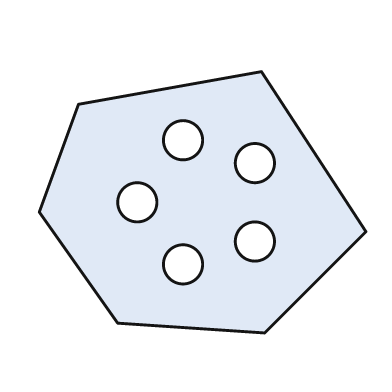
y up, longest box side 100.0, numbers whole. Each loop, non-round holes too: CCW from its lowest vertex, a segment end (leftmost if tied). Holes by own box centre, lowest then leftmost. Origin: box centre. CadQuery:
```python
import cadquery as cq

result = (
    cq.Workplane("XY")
    .moveTo(19.0, -40.0)
    .lineTo(50.0, -9.0)
    .lineTo(18.0, 40.0)
    .lineTo(-38.0, 30.0)
    .lineTo(-50.0, -3.0)
    .lineTo(-26.0, -37.0)
    .close()
    .moveTo(-6.0, -19.0)
    .circle(6.0)
    .moveTo(16.0, -12.0)
    .circle(6.0)
    .moveTo(-20.0, 0.0)
    .circle(6.0)
    .moveTo(16.0, 12.0)
    .circle(6.0)
    .moveTo(-6.0, 19.0)
    .circle(6.0)
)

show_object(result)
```